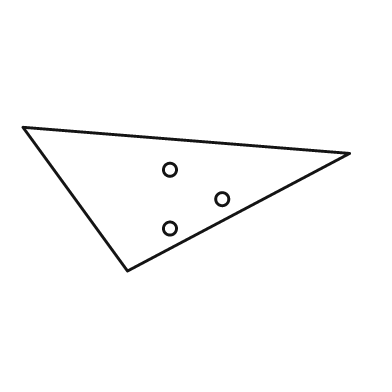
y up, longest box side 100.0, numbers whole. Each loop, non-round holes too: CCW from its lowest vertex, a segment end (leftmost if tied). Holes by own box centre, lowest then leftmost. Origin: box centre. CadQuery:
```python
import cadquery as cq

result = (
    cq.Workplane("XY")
    .moveTo(-18.0, -22.0)
    .lineTo(50.0, 14.0)
    .lineTo(-50.0, 22.0)
    .close()
    .moveTo(-5.0, -9.0)
    .circle(2.0)
    .moveTo(11.0, 0.0)
    .circle(2.0)
    .moveTo(-5.0, 9.0)
    .circle(2.0)
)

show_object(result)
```